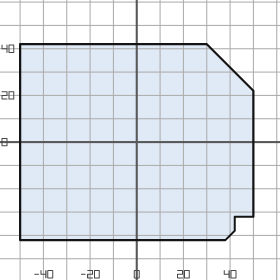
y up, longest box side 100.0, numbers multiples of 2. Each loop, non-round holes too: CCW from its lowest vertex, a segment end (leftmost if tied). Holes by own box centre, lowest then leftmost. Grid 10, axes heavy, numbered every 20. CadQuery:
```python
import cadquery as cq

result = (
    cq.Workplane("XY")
    .moveTo(-50.0, -42.0)
    .lineTo(38.0, -42.0)
    .lineTo(42.0, -38.0)
    .lineTo(42.0, -32.0)
    .lineTo(50.0, -32.0)
    .lineTo(50.0, 22.0)
    .lineTo(30.0, 42.0)
    .lineTo(-50.0, 42.0)
    .close()
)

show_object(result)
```